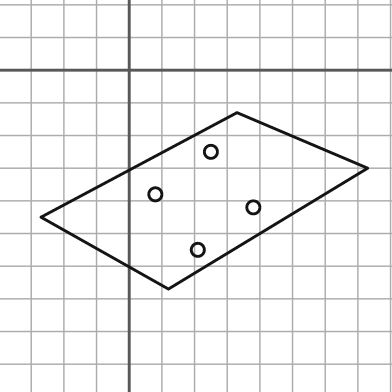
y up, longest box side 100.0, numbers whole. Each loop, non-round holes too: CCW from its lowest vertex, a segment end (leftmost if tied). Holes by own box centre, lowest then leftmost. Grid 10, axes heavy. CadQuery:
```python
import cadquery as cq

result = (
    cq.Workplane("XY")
    .moveTo(12.0, -67.0)
    .lineTo(73.0, -30.0)
    .lineTo(33.0, -13.0)
    .lineTo(-27.0, -45.0)
    .close()
    .moveTo(21.0, -55.0)
    .circle(2.0)
    .moveTo(38.0, -42.0)
    .circle(2.0)
    .moveTo(8.0, -38.0)
    .circle(2.0)
    .moveTo(25.0, -25.0)
    .circle(2.0)
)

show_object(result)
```